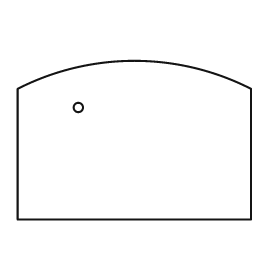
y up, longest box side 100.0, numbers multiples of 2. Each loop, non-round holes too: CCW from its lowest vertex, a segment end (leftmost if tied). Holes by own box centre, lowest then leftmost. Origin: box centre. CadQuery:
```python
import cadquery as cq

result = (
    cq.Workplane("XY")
    .moveTo(-50.0, -34.0)
    .lineTo(50.0, -34.0)
    .lineTo(50.0, 22.0)
    .threePointArc((0.0, 34.0), (-50.0, 22.0))
    .close()
    .moveTo(-24.0, 14.0)
    .circle(2.0)
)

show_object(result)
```